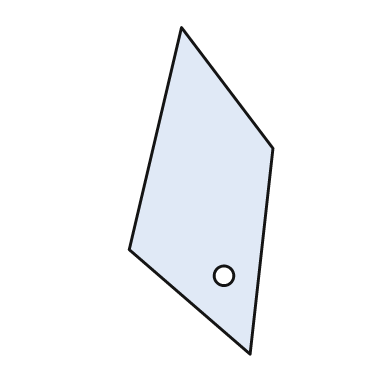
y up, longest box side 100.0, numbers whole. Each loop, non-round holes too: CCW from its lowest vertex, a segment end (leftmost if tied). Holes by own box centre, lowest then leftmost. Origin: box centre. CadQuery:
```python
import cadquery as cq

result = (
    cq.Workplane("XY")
    .moveTo(15.0, -50.0)
    .lineTo(22.0, 13.0)
    .lineTo(-6.0, 50.0)
    .lineTo(-22.0, -18.0)
    .close()
    .moveTo(7.0, -26.0)
    .circle(3.0)
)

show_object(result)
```